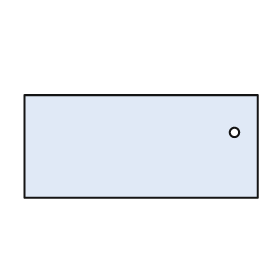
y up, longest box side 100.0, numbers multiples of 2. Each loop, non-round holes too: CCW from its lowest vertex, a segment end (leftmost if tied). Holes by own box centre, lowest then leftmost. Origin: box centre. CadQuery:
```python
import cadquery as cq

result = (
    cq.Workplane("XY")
    .moveTo(-50.0, -22.0)
    .lineTo(50.0, -22.0)
    .lineTo(50.0, 22.0)
    .lineTo(-50.0, 22.0)
    .close()
    .moveTo(40.0, 6.0)
    .circle(2.0)
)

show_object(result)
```